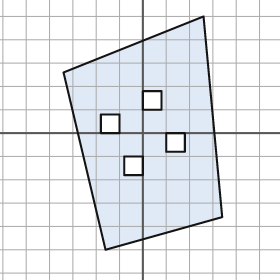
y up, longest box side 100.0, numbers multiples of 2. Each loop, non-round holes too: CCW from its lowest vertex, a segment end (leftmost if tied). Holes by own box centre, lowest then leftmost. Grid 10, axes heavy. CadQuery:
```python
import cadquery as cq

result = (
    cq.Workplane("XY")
    .moveTo(-16.0, -50.0)
    .lineTo(34.0, -36.0)
    .lineTo(26.0, 50.0)
    .lineTo(-34.0, 26.0)
    .close()
    .moveTo(-8.0, -18.0)
    .lineTo(0.0, -18.0)
    .lineTo(0.0, -10.0)
    .lineTo(-8.0, -10.0)
    .close()
    .moveTo(10.0, -8.0)
    .lineTo(18.0, -8.0)
    .lineTo(18.0, 0.0)
    .lineTo(10.0, 0.0)
    .close()
    .moveTo(-18.0, 0.0)
    .lineTo(-10.0, 0.0)
    .lineTo(-10.0, 8.0)
    .lineTo(-18.0, 8.0)
    .close()
    .moveTo(0.0, 10.0)
    .lineTo(8.0, 10.0)
    .lineTo(8.0, 18.0)
    .lineTo(0.0, 18.0)
    .close()
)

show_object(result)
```